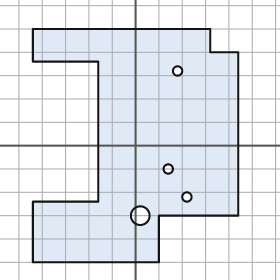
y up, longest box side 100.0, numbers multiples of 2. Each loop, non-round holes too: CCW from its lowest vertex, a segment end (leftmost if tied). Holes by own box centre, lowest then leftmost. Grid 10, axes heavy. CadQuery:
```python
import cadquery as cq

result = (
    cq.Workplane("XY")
    .moveTo(-44.0, -50.0)
    .lineTo(10.0, -50.0)
    .lineTo(10.0, -30.0)
    .lineTo(44.0, -30.0)
    .lineTo(44.0, 40.0)
    .lineTo(32.0, 40.0)
    .lineTo(32.0, 50.0)
    .lineTo(-44.0, 50.0)
    .lineTo(-44.0, 36.0)
    .lineTo(-16.0, 36.0)
    .lineTo(-16.0, -24.0)
    .lineTo(-44.0, -24.0)
    .close()
    .moveTo(2.0, -30.0)
    .circle(4.0)
    .moveTo(22.0, -22.0)
    .circle(2.0)
    .moveTo(14.0, -10.0)
    .circle(2.0)
    .moveTo(18.0, 32.0)
    .circle(2.0)
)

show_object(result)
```